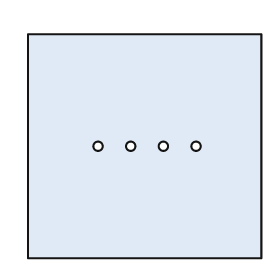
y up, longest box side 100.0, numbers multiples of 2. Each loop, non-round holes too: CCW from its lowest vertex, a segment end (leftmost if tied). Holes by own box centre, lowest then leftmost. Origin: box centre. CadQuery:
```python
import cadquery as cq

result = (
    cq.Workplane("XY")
    .moveTo(-50.0, -48.0)
    .lineTo(50.0, -48.0)
    .lineTo(50.0, 48.0)
    .lineTo(-50.0, 48.0)
    .close()
    .moveTo(-20.0, 0.0)
    .circle(2.0)
    .moveTo(-6.0, 0.0)
    .circle(2.0)
    .moveTo(8.0, 0.0)
    .circle(2.0)
    .moveTo(22.0, 0.0)
    .circle(2.0)
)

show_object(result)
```